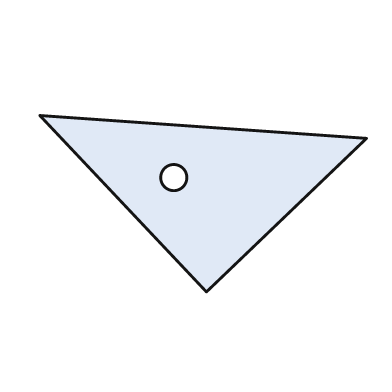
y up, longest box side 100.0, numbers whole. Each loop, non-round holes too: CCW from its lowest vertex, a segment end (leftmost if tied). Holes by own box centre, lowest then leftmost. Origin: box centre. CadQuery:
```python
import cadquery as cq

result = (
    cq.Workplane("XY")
    .moveTo(1.0, -27.0)
    .lineTo(50.0, 20.0)
    .lineTo(-50.0, 27.0)
    .close()
    .moveTo(-9.0, 8.0)
    .circle(4.0)
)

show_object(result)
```